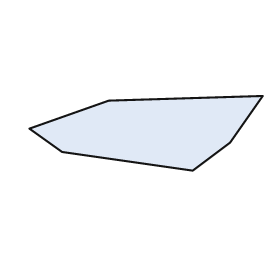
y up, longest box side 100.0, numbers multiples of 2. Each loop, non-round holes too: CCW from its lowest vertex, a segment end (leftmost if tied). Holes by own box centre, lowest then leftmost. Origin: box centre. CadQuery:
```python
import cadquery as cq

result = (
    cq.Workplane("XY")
    .moveTo(20.0, -16.0)
    .lineTo(36.0, -4.0)
    .lineTo(50.0, 16.0)
    .lineTo(-16.0, 14.0)
    .lineTo(-50.0, 2.0)
    .lineTo(-36.0, -8.0)
    .close()
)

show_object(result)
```